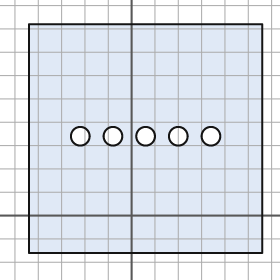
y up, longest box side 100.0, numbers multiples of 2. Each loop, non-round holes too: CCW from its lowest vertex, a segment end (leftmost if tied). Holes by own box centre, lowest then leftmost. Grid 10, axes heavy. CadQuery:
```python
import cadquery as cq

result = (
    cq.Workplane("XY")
    .moveTo(-44.0, -16.0)
    .lineTo(56.0, -16.0)
    .lineTo(56.0, 82.0)
    .lineTo(-44.0, 82.0)
    .close()
    .moveTo(-22.0, 34.0)
    .circle(4.0)
    .moveTo(-8.0, 34.0)
    .circle(4.0)
    .moveTo(6.0, 34.0)
    .circle(4.0)
    .moveTo(20.0, 34.0)
    .circle(4.0)
    .moveTo(34.0, 34.0)
    .circle(4.0)
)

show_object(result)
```